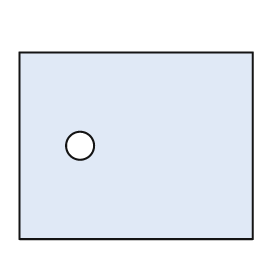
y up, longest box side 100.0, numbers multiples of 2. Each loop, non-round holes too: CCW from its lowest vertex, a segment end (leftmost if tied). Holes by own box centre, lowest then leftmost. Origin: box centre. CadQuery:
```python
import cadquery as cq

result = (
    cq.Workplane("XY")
    .moveTo(-50.0, -40.0)
    .lineTo(50.0, -40.0)
    .lineTo(50.0, 40.0)
    .lineTo(-50.0, 40.0)
    .close()
    .moveTo(-24.0, 0.0)
    .circle(6.0)
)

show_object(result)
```